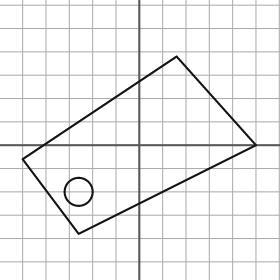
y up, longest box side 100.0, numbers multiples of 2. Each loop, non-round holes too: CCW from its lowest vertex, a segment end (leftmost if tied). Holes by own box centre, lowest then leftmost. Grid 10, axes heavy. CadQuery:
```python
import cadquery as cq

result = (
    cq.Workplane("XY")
    .moveTo(-26.0, -38.0)
    .lineTo(50.0, 0.0)
    .lineTo(16.0, 38.0)
    .lineTo(-50.0, -6.0)
    .close()
    .moveTo(-26.0, -20.0)
    .circle(6.0)
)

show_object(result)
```